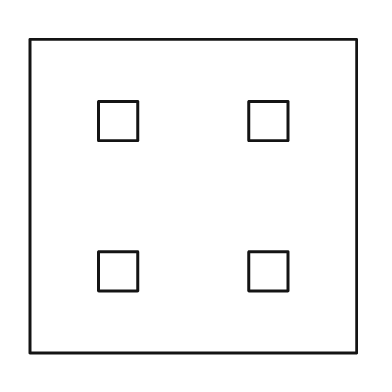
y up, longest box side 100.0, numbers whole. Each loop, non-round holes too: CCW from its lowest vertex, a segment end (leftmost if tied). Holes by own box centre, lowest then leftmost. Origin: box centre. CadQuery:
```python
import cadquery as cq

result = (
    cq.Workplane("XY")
    .moveTo(-50.0, -48.0)
    .lineTo(50.0, -48.0)
    .lineTo(50.0, 48.0)
    .lineTo(-50.0, 48.0)
    .close()
    .moveTo(-29.0, -29.0)
    .lineTo(-17.0, -29.0)
    .lineTo(-17.0, -17.0)
    .lineTo(-29.0, -17.0)
    .close()
    .moveTo(17.0, -29.0)
    .lineTo(29.0, -29.0)
    .lineTo(29.0, -17.0)
    .lineTo(17.0, -17.0)
    .close()
    .moveTo(-29.0, 17.0)
    .lineTo(-17.0, 17.0)
    .lineTo(-17.0, 29.0)
    .lineTo(-29.0, 29.0)
    .close()
    .moveTo(17.0, 17.0)
    .lineTo(29.0, 17.0)
    .lineTo(29.0, 29.0)
    .lineTo(17.0, 29.0)
    .close()
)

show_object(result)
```